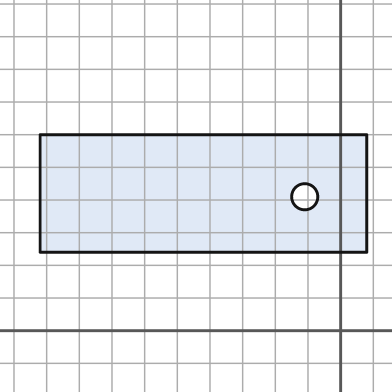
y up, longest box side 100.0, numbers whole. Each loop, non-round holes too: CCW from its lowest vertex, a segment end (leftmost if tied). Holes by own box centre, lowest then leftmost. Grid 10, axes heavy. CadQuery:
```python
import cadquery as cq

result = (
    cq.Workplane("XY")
    .moveTo(-92.0, 24.0)
    .lineTo(8.0, 24.0)
    .lineTo(8.0, 60.0)
    .lineTo(-92.0, 60.0)
    .close()
    .moveTo(-11.0, 41.0)
    .circle(4.0)
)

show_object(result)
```